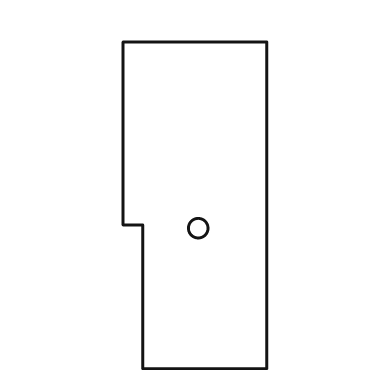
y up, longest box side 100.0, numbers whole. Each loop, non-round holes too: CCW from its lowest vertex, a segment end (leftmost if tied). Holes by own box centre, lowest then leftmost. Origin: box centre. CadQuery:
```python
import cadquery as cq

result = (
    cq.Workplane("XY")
    .moveTo(-16.0, -50.0)
    .lineTo(22.0, -50.0)
    .lineTo(22.0, 50.0)
    .lineTo(-22.0, 50.0)
    .lineTo(-22.0, -6.0)
    .lineTo(-16.0, -6.0)
    .close()
    .moveTo(1.0, -7.0)
    .circle(3.0)
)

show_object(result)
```